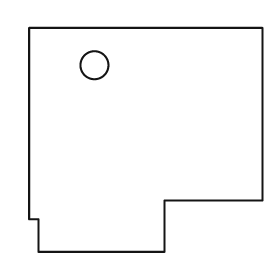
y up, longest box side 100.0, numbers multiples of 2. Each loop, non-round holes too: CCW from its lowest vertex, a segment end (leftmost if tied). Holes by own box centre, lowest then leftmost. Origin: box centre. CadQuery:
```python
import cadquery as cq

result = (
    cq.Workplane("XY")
    .moveTo(-46.0, -48.0)
    .lineTo(8.0, -48.0)
    .lineTo(8.0, -26.0)
    .lineTo(50.0, -26.0)
    .lineTo(50.0, 48.0)
    .lineTo(-50.0, 48.0)
    .lineTo(-50.0, -34.0)
    .lineTo(-46.0, -34.0)
    .close()
    .moveTo(-22.0, 32.0)
    .circle(6.0)
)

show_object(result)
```